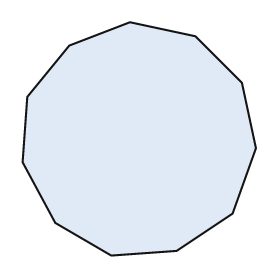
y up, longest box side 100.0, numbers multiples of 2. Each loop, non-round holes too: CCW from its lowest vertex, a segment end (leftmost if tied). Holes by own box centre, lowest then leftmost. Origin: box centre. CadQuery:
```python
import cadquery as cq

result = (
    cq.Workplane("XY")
    .moveTo(-12.0, -50.0)
    .lineTo(16.0, -48.0)
    .lineTo(40.0, -32.0)
    .lineTo(50.0, -4.0)
    .lineTo(44.0, 24.0)
    .lineTo(24.0, 44.0)
    .lineTo(-4.0, 50.0)
    .lineTo(-30.0, 40.0)
    .lineTo(-48.0, 18.0)
    .lineTo(-50.0, -10.0)
    .lineTo(-36.0, -36.0)
    .close()
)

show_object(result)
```